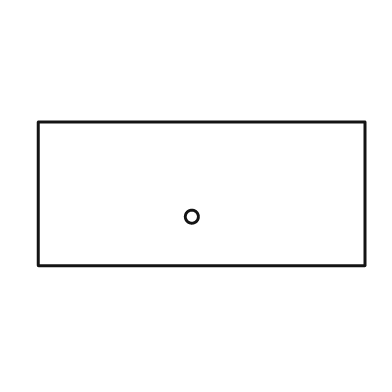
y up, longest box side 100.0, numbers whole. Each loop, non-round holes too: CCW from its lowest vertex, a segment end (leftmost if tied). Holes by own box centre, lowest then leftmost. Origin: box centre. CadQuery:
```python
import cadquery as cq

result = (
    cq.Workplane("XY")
    .moveTo(-50.0, -22.0)
    .lineTo(50.0, -22.0)
    .lineTo(50.0, 22.0)
    .lineTo(-50.0, 22.0)
    .close()
    .moveTo(-3.0, -7.0)
    .circle(2.0)
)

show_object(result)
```